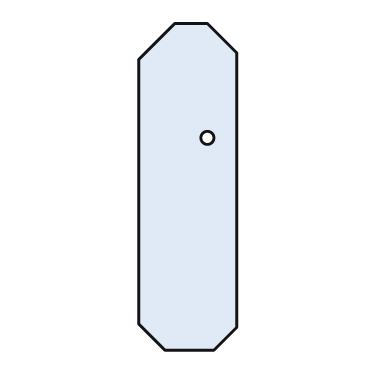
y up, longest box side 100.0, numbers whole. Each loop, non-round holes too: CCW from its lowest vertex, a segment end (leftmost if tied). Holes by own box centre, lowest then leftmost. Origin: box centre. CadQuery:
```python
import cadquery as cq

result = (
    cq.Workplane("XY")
    .moveTo(-7.0, -50.0)
    .lineTo(8.0, -50.0)
    .lineTo(15.0, -43.0)
    .lineTo(15.0, 41.0)
    .lineTo(6.0, 50.0)
    .lineTo(-4.0, 50.0)
    .lineTo(-15.0, 39.0)
    .lineTo(-15.0, -42.0)
    .close()
    .moveTo(6.0, 15.0)
    .circle(2.0)
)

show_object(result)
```